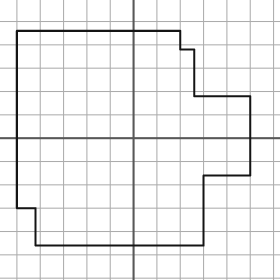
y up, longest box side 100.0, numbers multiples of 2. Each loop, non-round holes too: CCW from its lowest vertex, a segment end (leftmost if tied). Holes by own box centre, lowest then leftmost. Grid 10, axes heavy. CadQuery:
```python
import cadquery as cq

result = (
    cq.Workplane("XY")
    .moveTo(-42.0, -46.0)
    .lineTo(30.0, -46.0)
    .lineTo(30.0, -16.0)
    .lineTo(50.0, -16.0)
    .lineTo(50.0, 18.0)
    .lineTo(26.0, 18.0)
    .lineTo(26.0, 38.0)
    .lineTo(20.0, 38.0)
    .lineTo(20.0, 46.0)
    .lineTo(-50.0, 46.0)
    .lineTo(-50.0, -30.0)
    .lineTo(-42.0, -30.0)
    .close()
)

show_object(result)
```